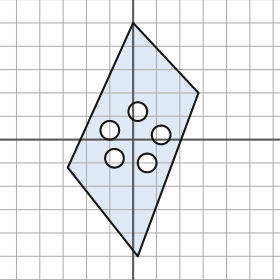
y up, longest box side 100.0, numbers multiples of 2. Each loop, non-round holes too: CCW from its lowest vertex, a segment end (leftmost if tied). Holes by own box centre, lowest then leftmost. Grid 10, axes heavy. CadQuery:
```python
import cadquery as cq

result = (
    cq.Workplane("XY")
    .moveTo(2.0, -50.0)
    .lineTo(28.0, 20.0)
    .lineTo(0.0, 50.0)
    .lineTo(-28.0, -12.0)
    .close()
    .moveTo(6.0, -10.0)
    .circle(4.0)
    .moveTo(-8.0, -8.0)
    .circle(4.0)
    .moveTo(12.0, 2.0)
    .circle(4.0)
    .moveTo(-10.0, 4.0)
    .circle(4.0)
    .moveTo(2.0, 12.0)
    .circle(4.0)
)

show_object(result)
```